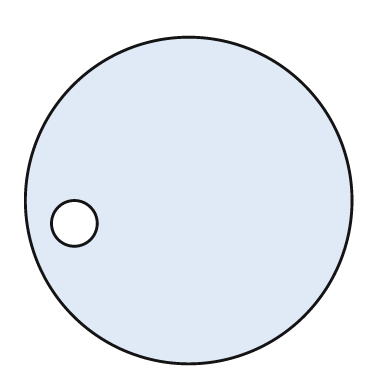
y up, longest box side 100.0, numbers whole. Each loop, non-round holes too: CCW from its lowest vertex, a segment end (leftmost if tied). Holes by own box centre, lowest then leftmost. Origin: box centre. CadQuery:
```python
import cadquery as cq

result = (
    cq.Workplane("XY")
    .moveTo(0.0, 0.0)
    .circle(50.0)
    .moveTo(-35.0, -7.0)
    .circle(7.0)
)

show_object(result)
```